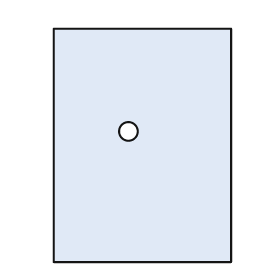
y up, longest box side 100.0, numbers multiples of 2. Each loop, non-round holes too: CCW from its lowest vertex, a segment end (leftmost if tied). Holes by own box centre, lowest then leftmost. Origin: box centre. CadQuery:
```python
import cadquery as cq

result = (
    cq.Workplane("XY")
    .moveTo(-38.0, -50.0)
    .lineTo(38.0, -50.0)
    .lineTo(38.0, 50.0)
    .lineTo(-38.0, 50.0)
    .close()
    .moveTo(-6.0, 6.0)
    .circle(4.0)
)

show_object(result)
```